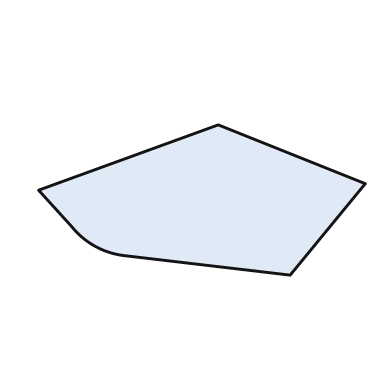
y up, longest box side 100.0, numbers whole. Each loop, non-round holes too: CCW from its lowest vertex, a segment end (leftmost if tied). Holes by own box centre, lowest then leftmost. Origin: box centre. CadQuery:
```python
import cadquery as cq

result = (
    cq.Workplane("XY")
    .moveTo(27.0, -23.0)
    .lineTo(50.0, 5.0)
    .lineTo(5.0, 23.0)
    .lineTo(-50.0, 3.0)
    .lineTo(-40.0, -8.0)
    .threePointArc((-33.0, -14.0), (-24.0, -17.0))
    .close()
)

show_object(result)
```